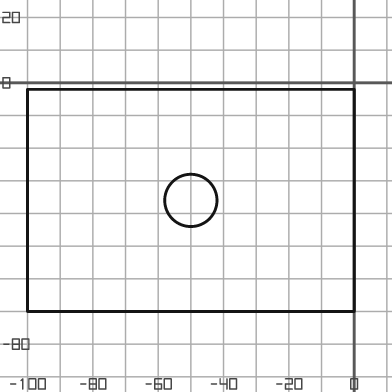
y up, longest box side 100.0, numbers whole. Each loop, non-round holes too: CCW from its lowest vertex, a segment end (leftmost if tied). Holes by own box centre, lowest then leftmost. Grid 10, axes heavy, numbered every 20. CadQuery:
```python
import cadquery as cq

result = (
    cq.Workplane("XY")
    .moveTo(-100.0, -70.0)
    .lineTo(0.0, -70.0)
    .lineTo(0.0, -2.0)
    .lineTo(-100.0, -2.0)
    .close()
    .moveTo(-50.0, -36.0)
    .circle(8.0)
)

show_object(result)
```